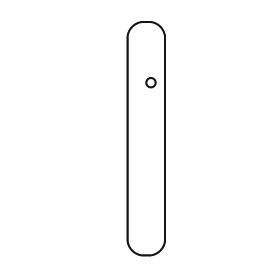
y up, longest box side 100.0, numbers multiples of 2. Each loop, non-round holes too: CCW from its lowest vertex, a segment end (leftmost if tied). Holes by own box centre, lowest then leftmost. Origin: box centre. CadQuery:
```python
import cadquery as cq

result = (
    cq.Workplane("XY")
    .moveTo(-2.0, -50.0)
    .lineTo(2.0, -50.0)
    .threePointArc((6.0, -48.0), (8.0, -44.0))
    .lineTo(8.0, 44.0)
    .threePointArc((6.0, 48.0), (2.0, 50.0))
    .lineTo(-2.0, 50.0)
    .threePointArc((-6.0, 48.0), (-8.0, 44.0))
    .lineTo(-8.0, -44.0)
    .threePointArc((-6.0, -48.0), (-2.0, -50.0))
    .close()
    .moveTo(2.0, 24.0)
    .circle(2.0)
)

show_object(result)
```